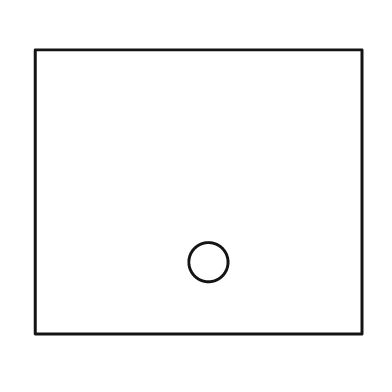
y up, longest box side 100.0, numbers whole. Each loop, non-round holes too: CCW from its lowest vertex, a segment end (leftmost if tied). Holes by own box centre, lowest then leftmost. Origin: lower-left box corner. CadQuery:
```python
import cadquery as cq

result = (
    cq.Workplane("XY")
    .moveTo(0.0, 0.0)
    .lineTo(100.0, 0.0)
    .lineTo(100.0, 87.0)
    .lineTo(0.0, 87.0)
    .close()
    .moveTo(53.0, 22.0)
    .circle(6.0)
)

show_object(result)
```